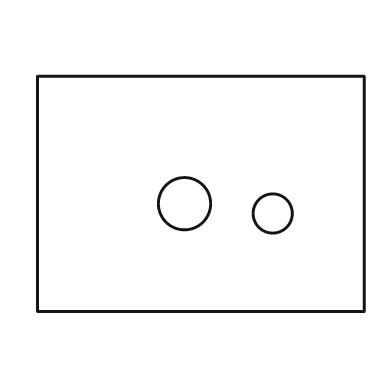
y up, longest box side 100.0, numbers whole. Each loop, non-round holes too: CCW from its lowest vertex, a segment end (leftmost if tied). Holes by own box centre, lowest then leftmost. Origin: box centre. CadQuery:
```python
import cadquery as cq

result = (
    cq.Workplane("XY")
    .moveTo(-50.0, -36.0)
    .lineTo(50.0, -36.0)
    .lineTo(50.0, 36.0)
    .lineTo(-50.0, 36.0)
    .close()
    .moveTo(22.0, -6.0)
    .circle(6.0)
    .moveTo(-5.0, -3.0)
    .circle(8.0)
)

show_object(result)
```